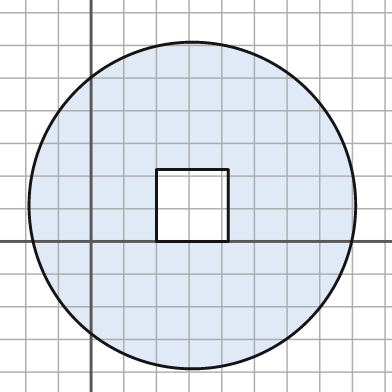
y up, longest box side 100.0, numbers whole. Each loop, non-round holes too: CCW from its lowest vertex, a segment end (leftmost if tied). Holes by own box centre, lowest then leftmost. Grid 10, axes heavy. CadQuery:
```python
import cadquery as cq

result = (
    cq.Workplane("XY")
    .moveTo(31.0, 11.0)
    .circle(50.0)
    .moveTo(20.0, 0.0)
    .lineTo(42.0, 0.0)
    .lineTo(42.0, 22.0)
    .lineTo(20.0, 22.0)
    .close()
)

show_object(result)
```